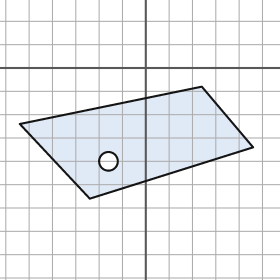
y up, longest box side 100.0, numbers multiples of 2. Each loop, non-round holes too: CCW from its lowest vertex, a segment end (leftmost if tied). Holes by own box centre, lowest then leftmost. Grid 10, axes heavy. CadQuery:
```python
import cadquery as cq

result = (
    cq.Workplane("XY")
    .moveTo(-24.0, -56.0)
    .lineTo(46.0, -34.0)
    .lineTo(24.0, -8.0)
    .lineTo(-54.0, -24.0)
    .close()
    .moveTo(-16.0, -40.0)
    .circle(4.0)
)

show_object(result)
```